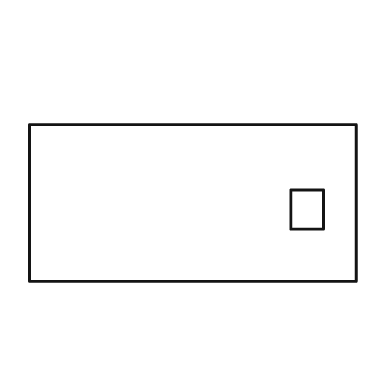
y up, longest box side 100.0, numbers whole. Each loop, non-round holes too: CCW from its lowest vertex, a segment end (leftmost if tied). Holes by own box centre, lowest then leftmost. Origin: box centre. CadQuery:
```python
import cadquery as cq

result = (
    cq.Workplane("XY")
    .moveTo(-50.0, -24.0)
    .lineTo(50.0, -24.0)
    .lineTo(50.0, 24.0)
    .lineTo(-50.0, 24.0)
    .close()
    .moveTo(30.0, -8.0)
    .lineTo(40.0, -8.0)
    .lineTo(40.0, 4.0)
    .lineTo(30.0, 4.0)
    .close()
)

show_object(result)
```